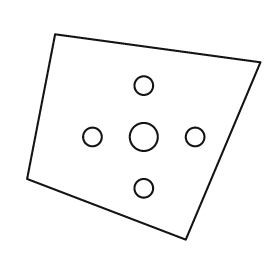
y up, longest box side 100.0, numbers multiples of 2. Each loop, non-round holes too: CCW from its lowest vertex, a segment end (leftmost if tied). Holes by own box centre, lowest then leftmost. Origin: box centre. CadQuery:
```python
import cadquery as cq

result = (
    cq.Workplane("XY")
    .moveTo(18.0, -44.0)
    .lineTo(50.0, 32.0)
    .lineTo(-38.0, 44.0)
    .lineTo(-50.0, -18.0)
    .close()
    .moveTo(0.0, -22.0)
    .circle(4.0)
    .moveTo(-22.0, 0.0)
    .circle(4.0)
    .moveTo(0.0, 0.0)
    .circle(6.0)
    .moveTo(22.0, 0.0)
    .circle(4.0)
    .moveTo(0.0, 22.0)
    .circle(4.0)
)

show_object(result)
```